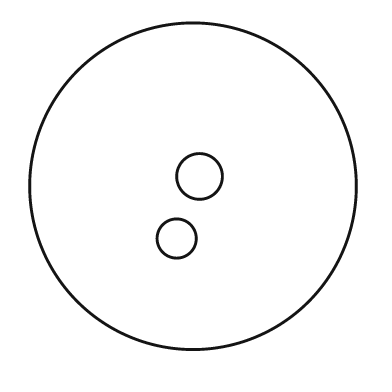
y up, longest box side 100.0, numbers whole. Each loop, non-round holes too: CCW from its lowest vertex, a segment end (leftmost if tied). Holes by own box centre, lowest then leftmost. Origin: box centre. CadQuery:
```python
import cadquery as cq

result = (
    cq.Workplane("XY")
    .moveTo(0.0, 0.0)
    .circle(50.0)
    .moveTo(-5.0, -16.0)
    .circle(6.0)
    .moveTo(2.0, 3.0)
    .circle(7.0)
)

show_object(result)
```